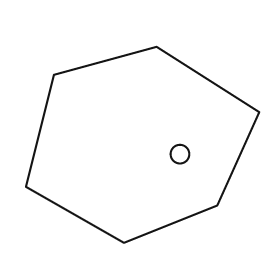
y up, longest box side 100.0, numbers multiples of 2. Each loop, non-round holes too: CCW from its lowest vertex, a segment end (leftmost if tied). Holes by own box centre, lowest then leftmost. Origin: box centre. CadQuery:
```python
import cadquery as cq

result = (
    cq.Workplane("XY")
    .moveTo(-8.0, -42.0)
    .lineTo(32.0, -26.0)
    .lineTo(50.0, 14.0)
    .lineTo(6.0, 42.0)
    .lineTo(-38.0, 30.0)
    .lineTo(-50.0, -18.0)
    .close()
    .moveTo(16.0, -4.0)
    .circle(4.0)
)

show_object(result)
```